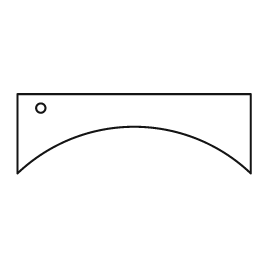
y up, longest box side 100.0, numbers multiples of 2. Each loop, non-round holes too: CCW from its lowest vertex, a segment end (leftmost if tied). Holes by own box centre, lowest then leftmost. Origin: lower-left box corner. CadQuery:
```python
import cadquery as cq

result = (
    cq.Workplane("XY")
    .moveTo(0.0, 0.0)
    .threePointArc((50.0, 20.0), (100.0, 0.0))
    .lineTo(100.0, 34.0)
    .lineTo(0.0, 34.0)
    .close()
    .moveTo(10.0, 28.0)
    .circle(2.0)
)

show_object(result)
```